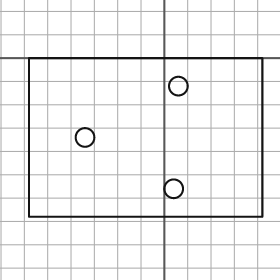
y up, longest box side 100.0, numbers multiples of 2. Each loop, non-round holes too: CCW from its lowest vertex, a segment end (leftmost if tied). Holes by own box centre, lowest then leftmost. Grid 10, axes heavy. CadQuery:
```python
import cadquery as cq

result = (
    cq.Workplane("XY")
    .moveTo(-58.0, -68.0)
    .lineTo(42.0, -68.0)
    .lineTo(42.0, 0.0)
    .lineTo(-58.0, 0.0)
    .close()
    .moveTo(4.0, -56.0)
    .circle(4.0)
    .moveTo(-34.0, -34.0)
    .circle(4.0)
    .moveTo(6.0, -12.0)
    .circle(4.0)
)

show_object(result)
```